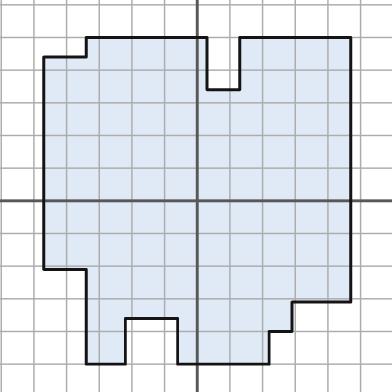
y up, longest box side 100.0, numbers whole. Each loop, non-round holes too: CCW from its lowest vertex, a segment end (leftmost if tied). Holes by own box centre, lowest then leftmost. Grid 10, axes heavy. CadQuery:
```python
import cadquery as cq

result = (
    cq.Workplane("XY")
    .moveTo(-34.0, -50.0)
    .lineTo(-22.0, -50.0)
    .lineTo(-22.0, -36.0)
    .lineTo(-6.0, -36.0)
    .lineTo(-6.0, -50.0)
    .lineTo(22.0, -50.0)
    .lineTo(22.0, -40.0)
    .lineTo(29.0, -40.0)
    .lineTo(29.0, -31.0)
    .lineTo(47.0, -31.0)
    .lineTo(47.0, 50.0)
    .lineTo(13.0, 50.0)
    .lineTo(13.0, 34.0)
    .lineTo(3.0, 34.0)
    .lineTo(3.0, 50.0)
    .lineTo(-34.0, 50.0)
    .lineTo(-34.0, 44.0)
    .lineTo(-47.0, 44.0)
    .lineTo(-47.0, -21.0)
    .lineTo(-34.0, -21.0)
    .close()
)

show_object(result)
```